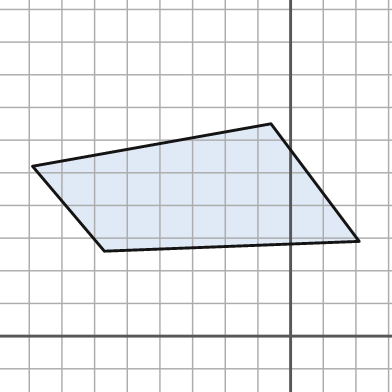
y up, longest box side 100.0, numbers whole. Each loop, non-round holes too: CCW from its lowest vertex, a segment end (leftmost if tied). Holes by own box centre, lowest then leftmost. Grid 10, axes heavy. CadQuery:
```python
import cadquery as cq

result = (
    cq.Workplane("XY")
    .moveTo(-57.0, 26.0)
    .lineTo(21.0, 29.0)
    .lineTo(-6.0, 65.0)
    .lineTo(-79.0, 52.0)
    .close()
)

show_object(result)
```